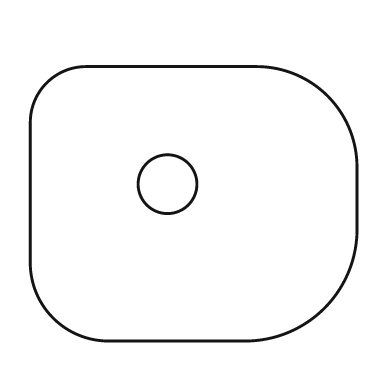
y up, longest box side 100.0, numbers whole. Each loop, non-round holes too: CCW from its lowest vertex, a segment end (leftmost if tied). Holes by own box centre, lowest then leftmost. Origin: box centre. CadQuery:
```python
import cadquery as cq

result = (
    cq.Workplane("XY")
    .moveTo(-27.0, -42.0)
    .lineTo(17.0, -42.0)
    .threePointArc((40.0, -32.0), (50.0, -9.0))
    .lineTo(50.0, 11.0)
    .threePointArc((41.0, 33.0), (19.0, 42.0))
    .lineTo(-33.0, 42.0)
    .threePointArc((-45.0, 37.0), (-50.0, 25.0))
    .lineTo(-50.0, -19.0)
    .threePointArc((-43.0, -35.0), (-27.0, -42.0))
    .close()
    .moveTo(-8.0, 6.0)
    .circle(9.0)
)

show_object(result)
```